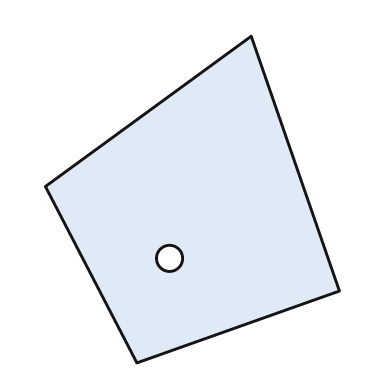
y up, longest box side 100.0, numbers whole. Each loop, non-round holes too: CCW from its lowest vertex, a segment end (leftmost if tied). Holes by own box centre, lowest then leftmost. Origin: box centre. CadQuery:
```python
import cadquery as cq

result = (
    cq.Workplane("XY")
    .moveTo(-17.0, -50.0)
    .lineTo(45.0, -28.0)
    .lineTo(18.0, 50.0)
    .lineTo(-45.0, 4.0)
    .close()
    .moveTo(-7.0, -18.0)
    .circle(4.0)
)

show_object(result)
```